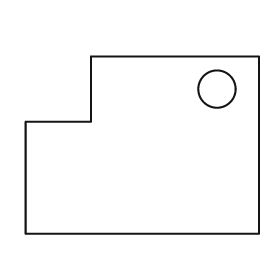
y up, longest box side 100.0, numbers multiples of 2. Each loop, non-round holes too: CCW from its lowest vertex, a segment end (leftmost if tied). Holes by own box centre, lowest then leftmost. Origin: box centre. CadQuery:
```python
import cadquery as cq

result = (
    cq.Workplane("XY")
    .moveTo(-50.0, -38.0)
    .lineTo(50.0, -38.0)
    .lineTo(50.0, 38.0)
    .lineTo(-22.0, 38.0)
    .lineTo(-22.0, 10.0)
    .lineTo(-50.0, 10.0)
    .close()
    .moveTo(32.0, 24.0)
    .circle(8.0)
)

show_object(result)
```